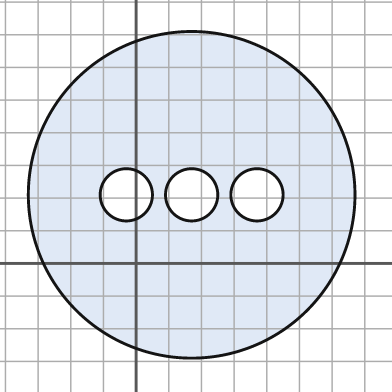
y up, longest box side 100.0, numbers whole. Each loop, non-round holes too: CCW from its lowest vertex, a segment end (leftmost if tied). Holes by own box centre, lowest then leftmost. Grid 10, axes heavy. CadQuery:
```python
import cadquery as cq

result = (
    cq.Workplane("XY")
    .moveTo(17.0, 21.0)
    .circle(50.0)
    .moveTo(-3.0, 21.0)
    .circle(8.0)
    .moveTo(17.0, 21.0)
    .circle(8.0)
    .moveTo(37.0, 21.0)
    .circle(8.0)
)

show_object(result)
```